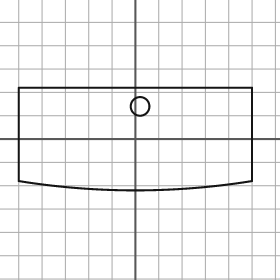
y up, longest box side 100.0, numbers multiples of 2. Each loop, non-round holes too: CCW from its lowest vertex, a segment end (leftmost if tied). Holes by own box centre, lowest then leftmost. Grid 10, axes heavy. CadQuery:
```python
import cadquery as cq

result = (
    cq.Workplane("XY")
    .moveTo(-50.0, -18.0)
    .threePointArc((0.0, -22.0), (50.0, -18.0))
    .lineTo(50.0, 22.0)
    .lineTo(-50.0, 22.0)
    .close()
    .moveTo(2.0, 14.0)
    .circle(4.0)
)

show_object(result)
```